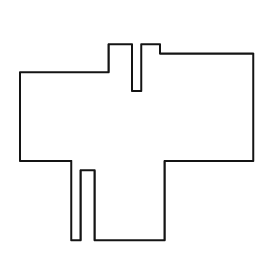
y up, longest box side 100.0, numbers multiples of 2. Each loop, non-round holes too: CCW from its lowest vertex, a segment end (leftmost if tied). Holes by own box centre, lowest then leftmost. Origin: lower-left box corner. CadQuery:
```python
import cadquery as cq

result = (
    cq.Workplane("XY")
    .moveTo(22.0, 0.0)
    .lineTo(26.0, 0.0)
    .lineTo(26.0, 30.0)
    .lineTo(32.0, 30.0)
    .lineTo(32.0, 0.0)
    .lineTo(62.0, 0.0)
    .lineTo(62.0, 34.0)
    .lineTo(100.0, 34.0)
    .lineTo(100.0, 80.0)
    .lineTo(60.0, 80.0)
    .lineTo(60.0, 84.0)
    .lineTo(52.0, 84.0)
    .lineTo(52.0, 64.0)
    .lineTo(48.0, 64.0)
    .lineTo(48.0, 84.0)
    .lineTo(38.0, 84.0)
    .lineTo(38.0, 72.0)
    .lineTo(0.0, 72.0)
    .lineTo(0.0, 34.0)
    .lineTo(22.0, 34.0)
    .close()
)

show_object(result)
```